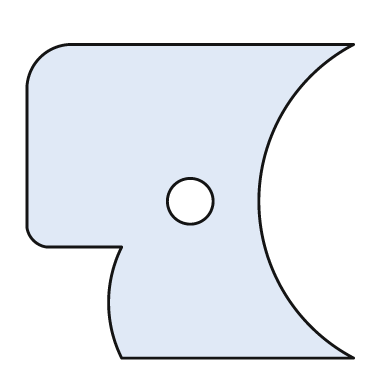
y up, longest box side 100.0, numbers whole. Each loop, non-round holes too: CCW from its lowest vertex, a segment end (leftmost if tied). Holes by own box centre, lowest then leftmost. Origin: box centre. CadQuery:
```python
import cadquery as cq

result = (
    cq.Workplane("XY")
    .moveTo(-21.0, -48.0)
    .lineTo(50.0, -48.0)
    .threePointArc((21.0, 0.0), (50.0, 48.0))
    .lineTo(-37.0, 48.0)
    .threePointArc((-46.0, 44.0), (-50.0, 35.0))
    .lineTo(-50.0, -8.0)
    .threePointArc((-48.0, -12.0), (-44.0, -14.0))
    .lineTo(-21.0, -14.0)
    .threePointArc((-25.0, -31.0), (-21.0, -48.0))
    .close()
    .moveTo(0.0, 0.0)
    .circle(7.0)
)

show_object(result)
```